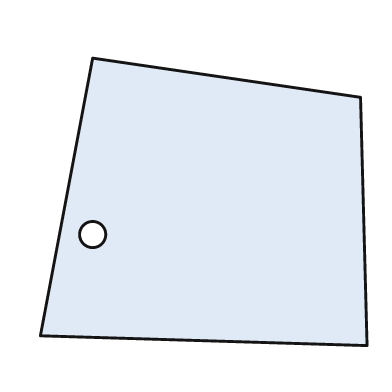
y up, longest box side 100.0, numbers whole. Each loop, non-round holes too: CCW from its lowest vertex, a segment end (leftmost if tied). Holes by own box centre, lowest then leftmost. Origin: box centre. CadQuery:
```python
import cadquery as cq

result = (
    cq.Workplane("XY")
    .moveTo(50.0, -44.0)
    .lineTo(48.0, 32.0)
    .lineTo(-34.0, 44.0)
    .lineTo(-50.0, -41.0)
    .close()
    .moveTo(-34.0, -10.0)
    .circle(4.0)
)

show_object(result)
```